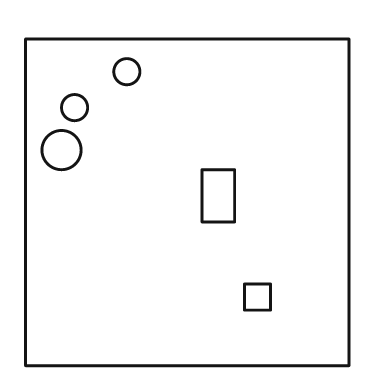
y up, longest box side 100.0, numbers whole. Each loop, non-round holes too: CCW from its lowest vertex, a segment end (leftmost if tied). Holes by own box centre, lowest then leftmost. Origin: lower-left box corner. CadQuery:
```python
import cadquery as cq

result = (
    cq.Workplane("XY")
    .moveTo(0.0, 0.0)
    .lineTo(99.0, 0.0)
    .lineTo(99.0, 100.0)
    .lineTo(0.0, 100.0)
    .close()
    .moveTo(67.0, 17.0)
    .lineTo(75.0, 17.0)
    .lineTo(75.0, 25.0)
    .lineTo(67.0, 25.0)
    .close()
    .moveTo(54.0, 44.0)
    .lineTo(64.0, 44.0)
    .lineTo(64.0, 60.0)
    .lineTo(54.0, 60.0)
    .close()
    .moveTo(11.0, 66.0)
    .circle(6.0)
    .moveTo(15.0, 79.0)
    .circle(4.0)
    .moveTo(31.0, 90.0)
    .circle(4.0)
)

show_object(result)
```